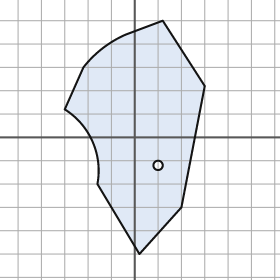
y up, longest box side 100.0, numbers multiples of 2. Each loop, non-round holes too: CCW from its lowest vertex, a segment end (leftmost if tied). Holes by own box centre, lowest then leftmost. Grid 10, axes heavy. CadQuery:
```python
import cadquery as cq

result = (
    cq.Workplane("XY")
    .moveTo(2.0, -50.0)
    .lineTo(20.0, -30.0)
    .lineTo(30.0, 22.0)
    .lineTo(12.0, 50.0)
    .lineTo(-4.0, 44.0)
    .threePointArc((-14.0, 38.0), (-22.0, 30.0))
    .lineTo(-30.0, 12.0)
    .threePointArc((-18.0, -2.0), (-16.0, -20.0))
    .close()
    .moveTo(10.0, -12.0)
    .circle(2.0)
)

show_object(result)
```